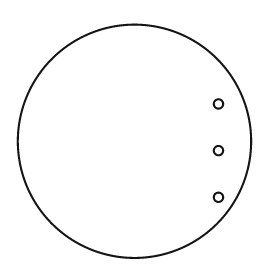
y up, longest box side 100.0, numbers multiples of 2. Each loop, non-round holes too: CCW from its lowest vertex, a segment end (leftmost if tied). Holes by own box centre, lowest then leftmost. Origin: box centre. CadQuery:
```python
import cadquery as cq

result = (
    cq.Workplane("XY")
    .moveTo(0.0, 0.0)
    .circle(50.0)
    .moveTo(36.0, -24.0)
    .circle(2.0)
    .moveTo(36.0, -4.0)
    .circle(2.0)
    .moveTo(36.0, 16.0)
    .circle(2.0)
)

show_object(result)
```